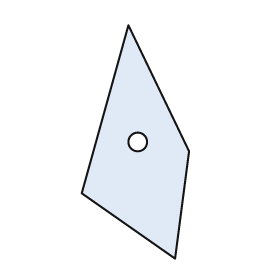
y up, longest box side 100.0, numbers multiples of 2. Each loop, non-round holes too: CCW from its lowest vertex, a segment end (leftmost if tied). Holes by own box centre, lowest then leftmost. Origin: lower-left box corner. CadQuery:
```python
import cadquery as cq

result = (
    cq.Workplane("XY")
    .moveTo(40.0, 0.0)
    .lineTo(46.0, 46.0)
    .lineTo(20.0, 100.0)
    .lineTo(0.0, 28.0)
    .close()
    .moveTo(24.0, 50.0)
    .circle(4.0)
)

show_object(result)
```